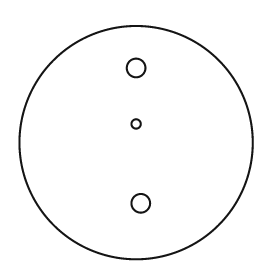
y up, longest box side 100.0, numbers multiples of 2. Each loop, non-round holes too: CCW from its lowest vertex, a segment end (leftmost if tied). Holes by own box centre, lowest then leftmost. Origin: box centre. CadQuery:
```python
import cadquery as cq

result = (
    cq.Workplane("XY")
    .moveTo(0.0, 0.0)
    .circle(50.0)
    .moveTo(2.0, -26.0)
    .circle(4.0)
    .moveTo(0.0, 8.0)
    .circle(2.0)
    .moveTo(0.0, 32.0)
    .circle(4.0)
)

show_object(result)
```